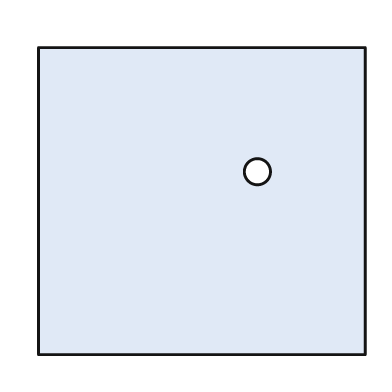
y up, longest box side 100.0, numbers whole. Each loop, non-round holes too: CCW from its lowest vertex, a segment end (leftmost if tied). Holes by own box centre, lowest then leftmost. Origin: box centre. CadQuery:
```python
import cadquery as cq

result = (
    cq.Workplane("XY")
    .moveTo(-50.0, -47.0)
    .lineTo(50.0, -47.0)
    .lineTo(50.0, 47.0)
    .lineTo(-50.0, 47.0)
    .close()
    .moveTo(17.0, 9.0)
    .circle(4.0)
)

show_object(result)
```